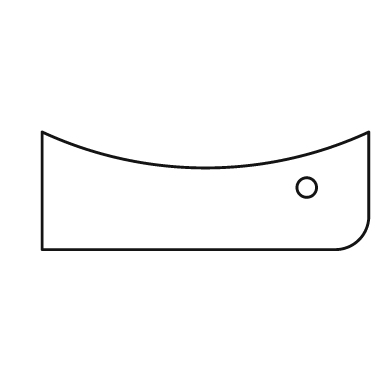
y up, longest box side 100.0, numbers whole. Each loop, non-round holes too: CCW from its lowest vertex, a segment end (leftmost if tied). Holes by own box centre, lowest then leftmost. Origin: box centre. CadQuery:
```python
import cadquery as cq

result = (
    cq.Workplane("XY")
    .moveTo(-50.0, -18.0)
    .lineTo(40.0, -18.0)
    .threePointArc((47.0, -15.0), (50.0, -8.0))
    .lineTo(50.0, 18.0)
    .threePointArc((0.0, 7.0), (-50.0, 18.0))
    .close()
    .moveTo(31.0, 1.0)
    .circle(3.0)
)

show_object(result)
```